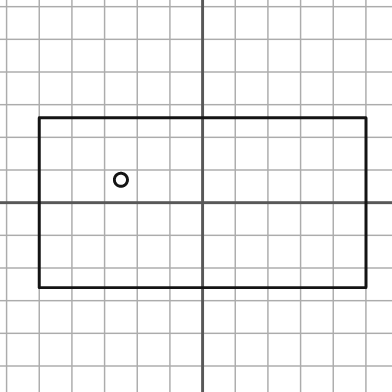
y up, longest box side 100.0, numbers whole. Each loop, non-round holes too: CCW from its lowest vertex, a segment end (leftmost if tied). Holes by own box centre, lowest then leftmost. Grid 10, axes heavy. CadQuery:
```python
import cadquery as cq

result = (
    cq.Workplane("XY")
    .moveTo(-50.0, -26.0)
    .lineTo(50.0, -26.0)
    .lineTo(50.0, 26.0)
    .lineTo(-50.0, 26.0)
    .close()
    .moveTo(-25.0, 7.0)
    .circle(2.0)
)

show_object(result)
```